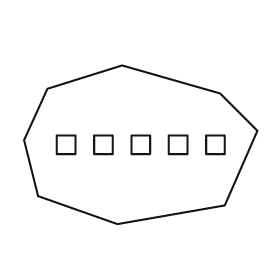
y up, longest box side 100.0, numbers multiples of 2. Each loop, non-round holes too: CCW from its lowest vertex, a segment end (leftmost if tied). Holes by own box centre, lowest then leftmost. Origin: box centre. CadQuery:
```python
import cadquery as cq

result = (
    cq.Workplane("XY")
    .moveTo(-10.0, -34.0)
    .lineTo(36.0, -26.0)
    .lineTo(50.0, 6.0)
    .lineTo(34.0, 22.0)
    .lineTo(-8.0, 34.0)
    .lineTo(-40.0, 24.0)
    .lineTo(-50.0, 2.0)
    .lineTo(-44.0, -22.0)
    .close()
    .moveTo(-36.0, -4.0)
    .lineTo(-28.0, -4.0)
    .lineTo(-28.0, 4.0)
    .lineTo(-36.0, 4.0)
    .close()
    .moveTo(-20.0, -4.0)
    .lineTo(-12.0, -4.0)
    .lineTo(-12.0, 4.0)
    .lineTo(-20.0, 4.0)
    .close()
    .moveTo(-4.0, -4.0)
    .lineTo(4.0, -4.0)
    .lineTo(4.0, 4.0)
    .lineTo(-4.0, 4.0)
    .close()
    .moveTo(12.0, -4.0)
    .lineTo(20.0, -4.0)
    .lineTo(20.0, 4.0)
    .lineTo(12.0, 4.0)
    .close()
    .moveTo(28.0, -4.0)
    .lineTo(36.0, -4.0)
    .lineTo(36.0, 4.0)
    .lineTo(28.0, 4.0)
    .close()
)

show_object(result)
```